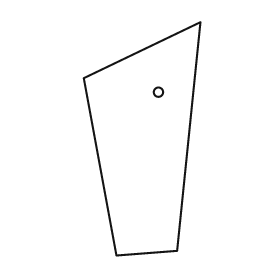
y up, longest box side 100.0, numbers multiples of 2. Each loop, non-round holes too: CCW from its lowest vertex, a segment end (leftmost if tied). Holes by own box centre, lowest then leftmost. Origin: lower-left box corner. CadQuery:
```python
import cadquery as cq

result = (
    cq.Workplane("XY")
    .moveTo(14.0, 0.0)
    .lineTo(40.0, 2.0)
    .lineTo(50.0, 100.0)
    .lineTo(0.0, 76.0)
    .close()
    .moveTo(32.0, 70.0)
    .circle(2.0)
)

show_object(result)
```